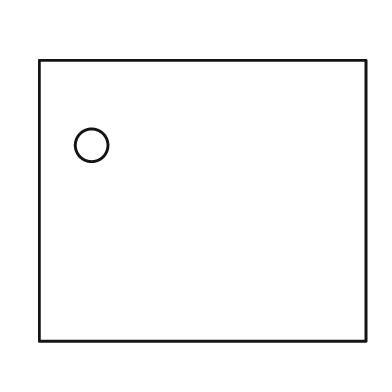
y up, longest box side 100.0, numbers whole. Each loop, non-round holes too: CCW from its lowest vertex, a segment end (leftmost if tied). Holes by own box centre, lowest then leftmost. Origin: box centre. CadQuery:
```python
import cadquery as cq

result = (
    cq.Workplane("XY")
    .moveTo(-50.0, -43.0)
    .lineTo(50.0, -43.0)
    .lineTo(50.0, 43.0)
    .lineTo(-50.0, 43.0)
    .close()
    .moveTo(-34.0, 17.0)
    .circle(5.0)
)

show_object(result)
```